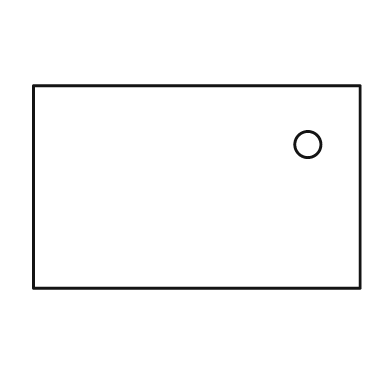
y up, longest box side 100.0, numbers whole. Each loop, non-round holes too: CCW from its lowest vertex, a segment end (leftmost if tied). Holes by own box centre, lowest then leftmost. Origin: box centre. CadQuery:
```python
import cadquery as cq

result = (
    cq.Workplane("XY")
    .moveTo(-50.0, -31.0)
    .lineTo(50.0, -31.0)
    .lineTo(50.0, 31.0)
    .lineTo(-50.0, 31.0)
    .close()
    .moveTo(34.0, 13.0)
    .circle(4.0)
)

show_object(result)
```